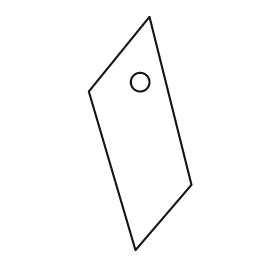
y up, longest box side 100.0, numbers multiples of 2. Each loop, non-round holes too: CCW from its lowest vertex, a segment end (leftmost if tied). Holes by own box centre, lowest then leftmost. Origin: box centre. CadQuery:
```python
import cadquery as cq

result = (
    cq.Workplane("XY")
    .moveTo(-2.0, -50.0)
    .lineTo(22.0, -22.0)
    .lineTo(4.0, 50.0)
    .lineTo(-22.0, 18.0)
    .close()
    .moveTo(0.0, 22.0)
    .circle(4.0)
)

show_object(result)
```